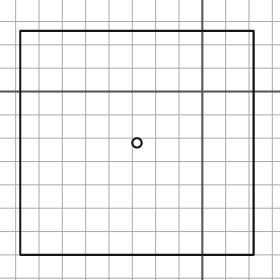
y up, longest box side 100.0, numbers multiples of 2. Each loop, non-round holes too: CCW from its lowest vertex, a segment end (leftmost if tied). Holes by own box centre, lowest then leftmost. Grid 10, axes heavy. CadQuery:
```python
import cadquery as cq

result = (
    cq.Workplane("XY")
    .moveTo(-78.0, -70.0)
    .lineTo(22.0, -70.0)
    .lineTo(22.0, 26.0)
    .lineTo(-78.0, 26.0)
    .close()
    .moveTo(-28.0, -22.0)
    .circle(2.0)
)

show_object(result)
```